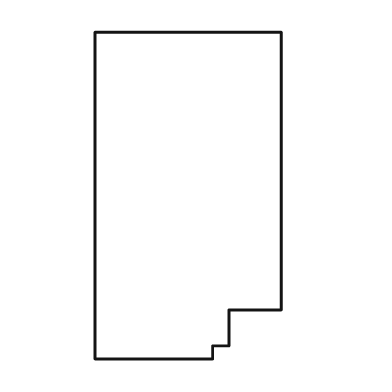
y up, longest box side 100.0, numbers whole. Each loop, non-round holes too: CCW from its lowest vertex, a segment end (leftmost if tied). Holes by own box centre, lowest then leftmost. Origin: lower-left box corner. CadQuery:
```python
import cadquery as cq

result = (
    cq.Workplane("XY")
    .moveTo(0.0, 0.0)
    .lineTo(36.0, 0.0)
    .lineTo(36.0, 4.0)
    .lineTo(41.0, 4.0)
    .lineTo(41.0, 15.0)
    .lineTo(57.0, 15.0)
    .lineTo(57.0, 100.0)
    .lineTo(0.0, 100.0)
    .close()
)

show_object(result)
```